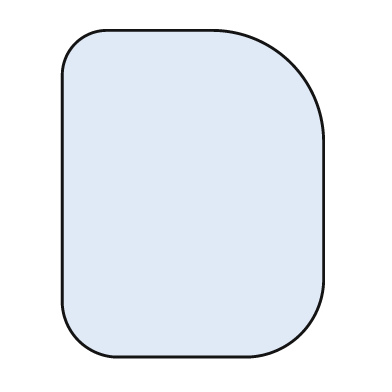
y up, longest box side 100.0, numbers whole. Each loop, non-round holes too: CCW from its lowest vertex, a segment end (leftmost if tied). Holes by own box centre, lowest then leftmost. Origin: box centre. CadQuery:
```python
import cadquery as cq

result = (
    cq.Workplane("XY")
    .moveTo(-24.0, -50.0)
    .lineTo(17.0, -50.0)
    .threePointArc((33.0, -43.0), (40.0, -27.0))
    .lineTo(40.0, 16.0)
    .threePointArc((30.0, 40.0), (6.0, 50.0))
    .lineTo(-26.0, 50.0)
    .threePointArc((-36.0, 46.0), (-40.0, 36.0))
    .lineTo(-40.0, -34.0)
    .threePointArc((-35.0, -45.0), (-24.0, -50.0))
    .close()
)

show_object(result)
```